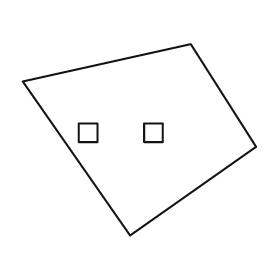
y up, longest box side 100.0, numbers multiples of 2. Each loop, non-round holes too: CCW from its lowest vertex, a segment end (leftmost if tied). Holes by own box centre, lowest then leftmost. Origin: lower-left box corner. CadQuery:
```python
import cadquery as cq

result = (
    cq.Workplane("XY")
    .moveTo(46.0, 0.0)
    .lineTo(100.0, 38.0)
    .lineTo(72.0, 82.0)
    .lineTo(0.0, 66.0)
    .close()
    .moveTo(24.0, 40.0)
    .lineTo(32.0, 40.0)
    .lineTo(32.0, 48.0)
    .lineTo(24.0, 48.0)
    .close()
    .moveTo(52.0, 40.0)
    .lineTo(60.0, 40.0)
    .lineTo(60.0, 48.0)
    .lineTo(52.0, 48.0)
    .close()
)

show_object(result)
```